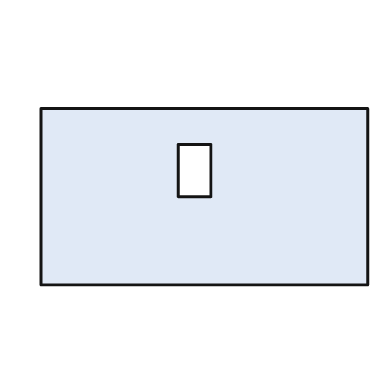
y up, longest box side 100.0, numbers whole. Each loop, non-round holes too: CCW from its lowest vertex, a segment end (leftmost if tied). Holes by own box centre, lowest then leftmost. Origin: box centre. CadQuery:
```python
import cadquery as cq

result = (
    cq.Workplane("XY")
    .moveTo(-50.0, -27.0)
    .lineTo(50.0, -27.0)
    .lineTo(50.0, 27.0)
    .lineTo(-50.0, 27.0)
    .close()
    .moveTo(-8.0, 0.0)
    .lineTo(2.0, 0.0)
    .lineTo(2.0, 16.0)
    .lineTo(-8.0, 16.0)
    .close()
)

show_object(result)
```